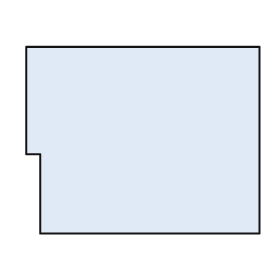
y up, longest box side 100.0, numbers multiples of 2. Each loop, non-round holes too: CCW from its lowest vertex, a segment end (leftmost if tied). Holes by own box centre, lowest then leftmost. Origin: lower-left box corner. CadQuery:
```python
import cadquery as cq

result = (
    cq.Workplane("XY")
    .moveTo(6.0, 0.0)
    .lineTo(100.0, 0.0)
    .lineTo(100.0, 80.0)
    .lineTo(0.0, 80.0)
    .lineTo(0.0, 34.0)
    .lineTo(6.0, 34.0)
    .close()
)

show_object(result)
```